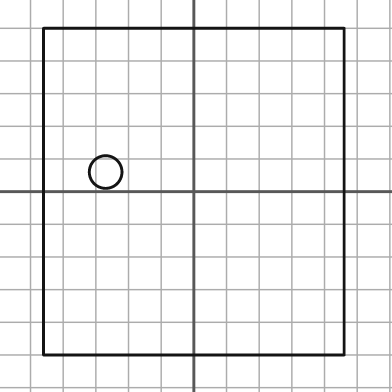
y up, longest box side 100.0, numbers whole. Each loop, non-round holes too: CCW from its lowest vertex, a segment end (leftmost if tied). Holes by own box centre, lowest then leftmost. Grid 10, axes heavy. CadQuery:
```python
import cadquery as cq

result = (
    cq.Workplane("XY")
    .moveTo(-46.0, -50.0)
    .lineTo(46.0, -50.0)
    .lineTo(46.0, 50.0)
    .lineTo(-46.0, 50.0)
    .close()
    .moveTo(-27.0, 6.0)
    .circle(5.0)
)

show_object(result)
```